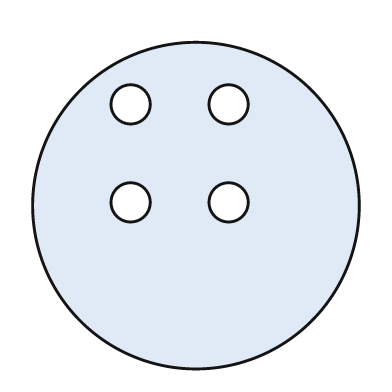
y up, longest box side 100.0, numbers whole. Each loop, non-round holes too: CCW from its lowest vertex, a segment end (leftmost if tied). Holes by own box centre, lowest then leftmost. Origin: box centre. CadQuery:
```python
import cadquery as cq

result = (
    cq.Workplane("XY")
    .moveTo(0.0, 0.0)
    .circle(50.0)
    .moveTo(-20.0, 1.0)
    .circle(6.0)
    .moveTo(10.0, 1.0)
    .circle(6.0)
    .moveTo(-20.0, 31.0)
    .circle(6.0)
    .moveTo(10.0, 31.0)
    .circle(6.0)
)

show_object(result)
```